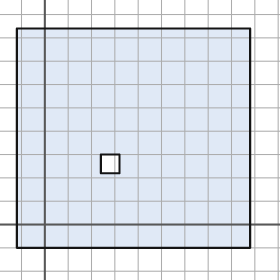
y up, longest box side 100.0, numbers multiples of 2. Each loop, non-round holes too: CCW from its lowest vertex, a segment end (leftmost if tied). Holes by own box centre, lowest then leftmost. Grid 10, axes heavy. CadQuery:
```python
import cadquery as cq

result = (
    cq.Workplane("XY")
    .moveTo(-12.0, -10.0)
    .lineTo(88.0, -10.0)
    .lineTo(88.0, 84.0)
    .lineTo(-12.0, 84.0)
    .close()
    .moveTo(24.0, 22.0)
    .lineTo(32.0, 22.0)
    .lineTo(32.0, 30.0)
    .lineTo(24.0, 30.0)
    .close()
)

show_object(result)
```